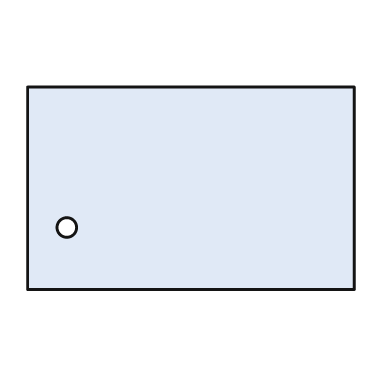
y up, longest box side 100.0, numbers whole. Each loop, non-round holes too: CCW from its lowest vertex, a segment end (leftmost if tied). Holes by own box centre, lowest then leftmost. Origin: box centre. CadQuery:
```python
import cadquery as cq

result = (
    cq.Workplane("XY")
    .moveTo(-50.0, -31.0)
    .lineTo(50.0, -31.0)
    .lineTo(50.0, 31.0)
    .lineTo(-50.0, 31.0)
    .close()
    .moveTo(-38.0, -12.0)
    .circle(3.0)
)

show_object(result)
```